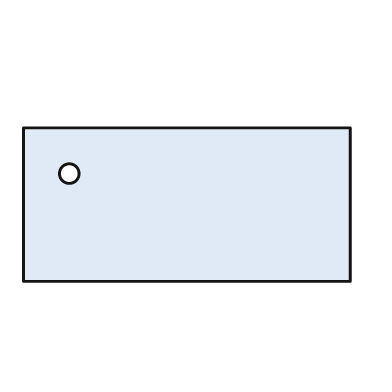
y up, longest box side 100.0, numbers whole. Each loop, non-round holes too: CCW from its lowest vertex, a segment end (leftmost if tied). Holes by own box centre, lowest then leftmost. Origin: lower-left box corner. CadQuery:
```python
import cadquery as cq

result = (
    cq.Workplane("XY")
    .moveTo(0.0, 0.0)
    .lineTo(100.0, 0.0)
    .lineTo(100.0, 47.0)
    .lineTo(0.0, 47.0)
    .close()
    .moveTo(14.0, 33.0)
    .circle(3.0)
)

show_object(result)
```